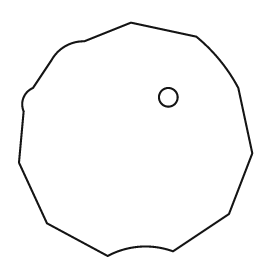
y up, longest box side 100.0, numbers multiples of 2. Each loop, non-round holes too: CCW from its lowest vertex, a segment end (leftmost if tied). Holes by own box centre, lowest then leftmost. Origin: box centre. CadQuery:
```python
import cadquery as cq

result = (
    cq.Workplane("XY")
    .moveTo(-12.0, -50.0)
    .threePointArc((2.0, -46.0), (16.0, -48.0))
    .lineTo(40.0, -32.0)
    .lineTo(50.0, -6.0)
    .lineTo(44.0, 22.0)
    .threePointArc((36.0, 34.0), (26.0, 44.0))
    .lineTo(-2.0, 50.0)
    .lineTo(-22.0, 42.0)
    .threePointArc((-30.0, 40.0), (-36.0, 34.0))
    .lineTo(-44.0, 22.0)
    .threePointArc((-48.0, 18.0), (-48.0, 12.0))
    .lineTo(-50.0, -10.0)
    .lineTo(-38.0, -36.0)
    .close()
    .moveTo(14.0, 18.0)
    .circle(4.0)
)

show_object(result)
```